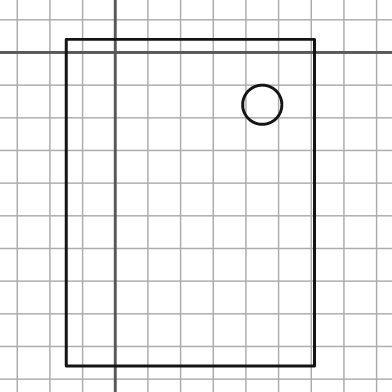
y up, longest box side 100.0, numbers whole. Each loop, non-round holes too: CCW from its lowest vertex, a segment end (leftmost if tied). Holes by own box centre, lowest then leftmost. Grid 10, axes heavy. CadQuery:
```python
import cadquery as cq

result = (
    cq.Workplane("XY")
    .moveTo(-15.0, -96.0)
    .lineTo(61.0, -96.0)
    .lineTo(61.0, 4.0)
    .lineTo(-15.0, 4.0)
    .close()
    .moveTo(45.0, -16.0)
    .circle(6.0)
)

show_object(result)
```